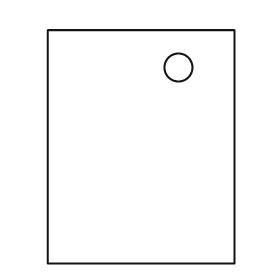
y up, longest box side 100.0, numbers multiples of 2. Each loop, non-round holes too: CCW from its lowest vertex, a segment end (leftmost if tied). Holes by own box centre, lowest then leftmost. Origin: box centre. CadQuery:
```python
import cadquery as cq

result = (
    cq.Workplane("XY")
    .moveTo(-40.0, -50.0)
    .lineTo(40.0, -50.0)
    .lineTo(40.0, 50.0)
    .lineTo(-40.0, 50.0)
    .close()
    .moveTo(16.0, 34.0)
    .circle(6.0)
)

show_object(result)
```